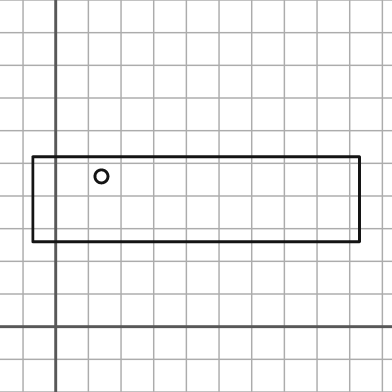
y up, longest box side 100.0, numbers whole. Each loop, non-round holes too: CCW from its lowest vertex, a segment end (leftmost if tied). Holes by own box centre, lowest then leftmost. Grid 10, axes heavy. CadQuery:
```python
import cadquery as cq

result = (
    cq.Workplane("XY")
    .moveTo(-7.0, 26.0)
    .lineTo(93.0, 26.0)
    .lineTo(93.0, 52.0)
    .lineTo(-7.0, 52.0)
    .close()
    .moveTo(14.0, 46.0)
    .circle(2.0)
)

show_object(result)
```